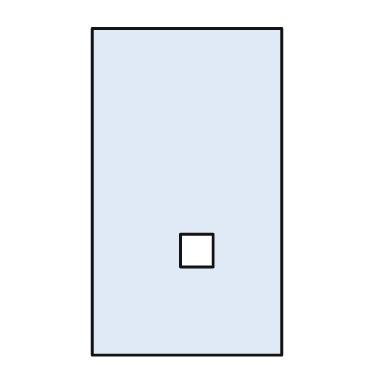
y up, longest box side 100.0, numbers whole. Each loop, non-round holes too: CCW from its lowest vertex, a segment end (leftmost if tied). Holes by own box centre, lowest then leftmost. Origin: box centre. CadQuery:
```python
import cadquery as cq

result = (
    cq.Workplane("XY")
    .moveTo(-29.0, -50.0)
    .lineTo(29.0, -50.0)
    .lineTo(29.0, 50.0)
    .lineTo(-29.0, 50.0)
    .close()
    .moveTo(-2.0, -23.0)
    .lineTo(8.0, -23.0)
    .lineTo(8.0, -13.0)
    .lineTo(-2.0, -13.0)
    .close()
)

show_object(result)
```